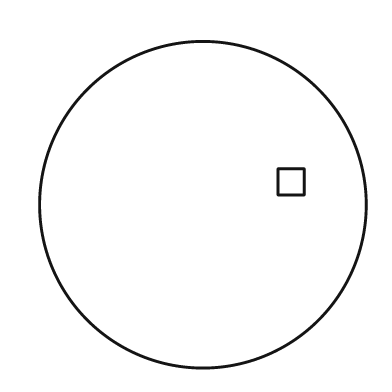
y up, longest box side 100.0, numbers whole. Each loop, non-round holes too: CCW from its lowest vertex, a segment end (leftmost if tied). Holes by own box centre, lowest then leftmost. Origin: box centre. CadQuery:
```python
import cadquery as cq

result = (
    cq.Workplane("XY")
    .moveTo(0.0, 0.0)
    .circle(50.0)
    .moveTo(23.0, 3.0)
    .lineTo(31.0, 3.0)
    .lineTo(31.0, 11.0)
    .lineTo(23.0, 11.0)
    .close()
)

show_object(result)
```